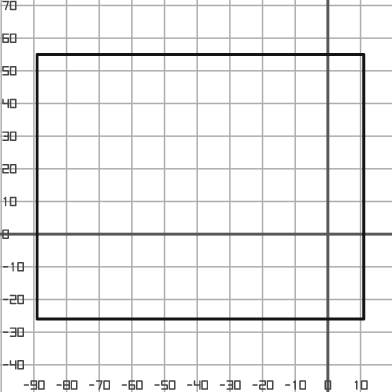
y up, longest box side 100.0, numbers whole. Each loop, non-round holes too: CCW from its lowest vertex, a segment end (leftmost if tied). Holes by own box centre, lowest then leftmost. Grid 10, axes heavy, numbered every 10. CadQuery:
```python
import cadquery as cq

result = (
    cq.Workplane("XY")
    .moveTo(-89.0, -26.0)
    .lineTo(11.0, -26.0)
    .lineTo(11.0, 55.0)
    .lineTo(-89.0, 55.0)
    .close()
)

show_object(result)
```